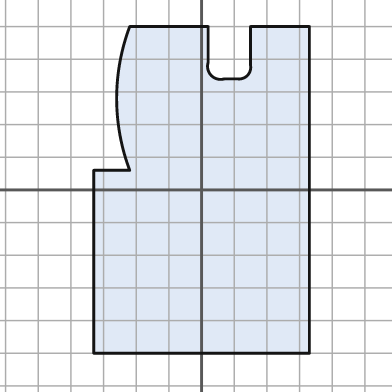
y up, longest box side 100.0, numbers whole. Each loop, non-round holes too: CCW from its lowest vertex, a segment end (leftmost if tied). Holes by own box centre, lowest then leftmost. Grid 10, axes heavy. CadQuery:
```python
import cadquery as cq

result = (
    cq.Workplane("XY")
    .moveTo(-33.0, -50.0)
    .lineTo(33.0, -50.0)
    .lineTo(33.0, 50.0)
    .lineTo(15.0, 50.0)
    .lineTo(15.0, 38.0)
    .threePointArc((14.0, 35.0), (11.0, 34.0))
    .lineTo(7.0, 34.0)
    .threePointArc((3.0, 35.0), (2.0, 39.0))
    .lineTo(2.0, 50.0)
    .lineTo(-22.0, 50.0)
    .threePointArc((-26.0, 28.0), (-22.0, 6.0))
    .lineTo(-33.0, 6.0)
    .close()
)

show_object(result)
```